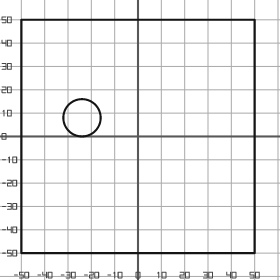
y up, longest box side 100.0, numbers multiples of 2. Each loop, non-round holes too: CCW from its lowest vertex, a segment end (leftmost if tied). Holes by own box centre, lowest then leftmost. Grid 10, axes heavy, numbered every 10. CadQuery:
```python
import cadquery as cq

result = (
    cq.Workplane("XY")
    .moveTo(-50.0, -50.0)
    .lineTo(50.0, -50.0)
    .lineTo(50.0, 50.0)
    .lineTo(-50.0, 50.0)
    .close()
    .moveTo(-24.0, 8.0)
    .circle(8.0)
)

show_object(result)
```